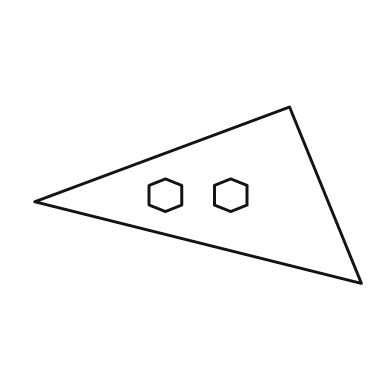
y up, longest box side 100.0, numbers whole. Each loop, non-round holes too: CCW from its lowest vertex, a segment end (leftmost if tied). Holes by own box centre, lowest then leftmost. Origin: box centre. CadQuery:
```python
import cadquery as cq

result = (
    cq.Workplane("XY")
    .moveTo(50.0, -27.0)
    .lineTo(28.0, 27.0)
    .lineTo(-50.0, -2.0)
    .close()
    .moveTo(-10.0, -5.0)
    .lineTo(-5.0, -3.0)
    .lineTo(-5.0, 3.0)
    .lineTo(-10.0, 5.0)
    .lineTo(-15.0, 3.0)
    .lineTo(-15.0, -3.0)
    .close()
    .moveTo(10.0, -5.0)
    .lineTo(15.0, -3.0)
    .lineTo(15.0, 3.0)
    .lineTo(10.0, 5.0)
    .lineTo(5.0, 3.0)
    .lineTo(5.0, -3.0)
    .close()
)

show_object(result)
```